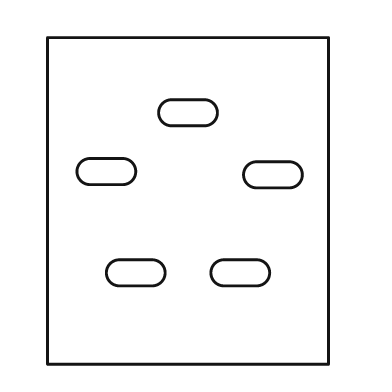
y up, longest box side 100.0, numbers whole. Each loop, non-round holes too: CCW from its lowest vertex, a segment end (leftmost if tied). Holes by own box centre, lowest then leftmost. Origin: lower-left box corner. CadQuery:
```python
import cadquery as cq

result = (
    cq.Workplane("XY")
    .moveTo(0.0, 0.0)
    .lineTo(86.0, 0.0)
    .lineTo(86.0, 100.0)
    .lineTo(0.0, 100.0)
    .close()
    .moveTo(22.0, 24.0)
    .lineTo(32.0, 24.0)
    .threePointArc((36.0, 28.0), (32.0, 32.0))
    .lineTo(22.0, 32.0)
    .threePointArc((18.0, 28.0), (22.0, 24.0))
    .close()
    .moveTo(54.0, 24.0)
    .lineTo(64.0, 24.0)
    .threePointArc((68.0, 28.0), (64.0, 32.0))
    .lineTo(54.0, 32.0)
    .threePointArc((50.0, 28.0), (54.0, 24.0))
    .close()
    .moveTo(64.0, 54.0)
    .lineTo(74.0, 54.0)
    .threePointArc((78.0, 58.0), (74.0, 62.0))
    .lineTo(64.0, 62.0)
    .threePointArc((60.0, 58.0), (64.0, 54.0))
    .close()
    .moveTo(13.0, 55.0)
    .lineTo(23.0, 55.0)
    .threePointArc((27.0, 59.0), (23.0, 63.0))
    .lineTo(13.0, 63.0)
    .threePointArc((9.0, 59.0), (13.0, 55.0))
    .close()
    .moveTo(38.0, 73.0)
    .lineTo(48.0, 73.0)
    .threePointArc((52.0, 77.0), (48.0, 81.0))
    .lineTo(38.0, 81.0)
    .threePointArc((34.0, 77.0), (38.0, 73.0))
    .close()
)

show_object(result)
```